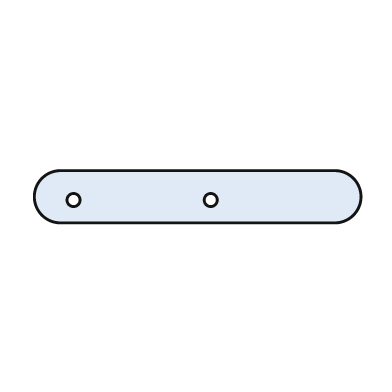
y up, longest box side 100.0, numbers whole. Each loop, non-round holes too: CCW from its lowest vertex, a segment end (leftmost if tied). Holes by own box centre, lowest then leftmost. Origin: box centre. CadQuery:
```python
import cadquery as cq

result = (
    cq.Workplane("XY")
    .moveTo(-42.0, -8.0)
    .lineTo(42.0, -8.0)
    .threePointArc((50.0, 0.0), (42.0, 8.0))
    .lineTo(-42.0, 8.0)
    .threePointArc((-50.0, 0.0), (-42.0, -8.0))
    .close()
    .moveTo(-38.0, -1.0)
    .circle(2.0)
    .moveTo(4.0, -1.0)
    .circle(2.0)
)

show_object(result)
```